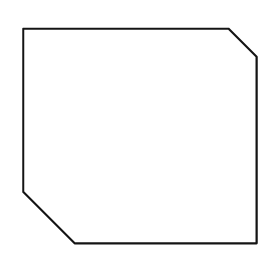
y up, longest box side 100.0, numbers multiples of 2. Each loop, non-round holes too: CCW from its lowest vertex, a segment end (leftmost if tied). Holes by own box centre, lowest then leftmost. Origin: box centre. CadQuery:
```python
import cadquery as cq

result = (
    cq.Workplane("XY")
    .moveTo(-28.0, -46.0)
    .lineTo(50.0, -46.0)
    .lineTo(50.0, 34.0)
    .lineTo(38.0, 46.0)
    .lineTo(-50.0, 46.0)
    .lineTo(-50.0, -24.0)
    .close()
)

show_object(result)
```